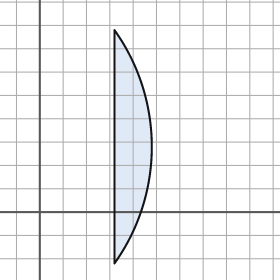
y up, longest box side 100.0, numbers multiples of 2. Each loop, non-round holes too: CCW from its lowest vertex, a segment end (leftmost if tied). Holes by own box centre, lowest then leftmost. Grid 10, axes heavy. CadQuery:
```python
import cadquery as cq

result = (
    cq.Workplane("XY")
    .moveTo(32.0, -22.0)
    .threePointArc((48.0, 28.0), (32.0, 78.0))
    .close()
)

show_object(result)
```